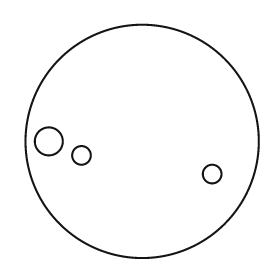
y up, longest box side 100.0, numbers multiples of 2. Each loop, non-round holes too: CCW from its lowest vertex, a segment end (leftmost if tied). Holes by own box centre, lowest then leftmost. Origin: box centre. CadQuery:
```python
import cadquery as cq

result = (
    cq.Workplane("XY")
    .moveTo(0.0, 0.0)
    .circle(50.0)
    .moveTo(30.0, -14.0)
    .circle(4.0)
    .moveTo(-26.0, -6.0)
    .circle(4.0)
    .moveTo(-40.0, 0.0)
    .circle(6.0)
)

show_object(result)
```